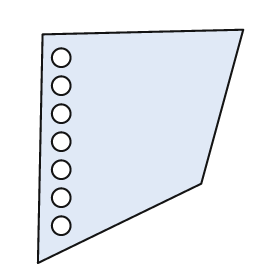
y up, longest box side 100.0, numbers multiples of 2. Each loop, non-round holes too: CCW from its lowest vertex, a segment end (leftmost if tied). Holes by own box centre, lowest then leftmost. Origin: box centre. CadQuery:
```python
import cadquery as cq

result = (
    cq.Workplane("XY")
    .moveTo(-44.0, -50.0)
    .lineTo(26.0, -16.0)
    .lineTo(44.0, 50.0)
    .lineTo(-42.0, 48.0)
    .close()
    .moveTo(-34.0, -34.0)
    .circle(4.0)
    .moveTo(-34.0, -22.0)
    .circle(4.0)
    .moveTo(-34.0, -10.0)
    .circle(4.0)
    .moveTo(-34.0, 2.0)
    .circle(4.0)
    .moveTo(-34.0, 14.0)
    .circle(4.0)
    .moveTo(-34.0, 26.0)
    .circle(4.0)
    .moveTo(-34.0, 38.0)
    .circle(4.0)
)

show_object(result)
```